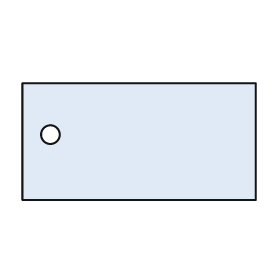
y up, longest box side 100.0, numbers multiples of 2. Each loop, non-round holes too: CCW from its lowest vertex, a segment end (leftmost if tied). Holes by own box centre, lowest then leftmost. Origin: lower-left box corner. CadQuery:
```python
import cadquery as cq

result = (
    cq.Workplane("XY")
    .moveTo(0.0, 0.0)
    .lineTo(100.0, 0.0)
    .lineTo(100.0, 50.0)
    .lineTo(0.0, 50.0)
    .close()
    .moveTo(12.0, 28.0)
    .circle(4.0)
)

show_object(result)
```